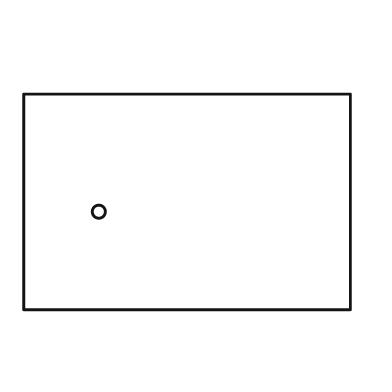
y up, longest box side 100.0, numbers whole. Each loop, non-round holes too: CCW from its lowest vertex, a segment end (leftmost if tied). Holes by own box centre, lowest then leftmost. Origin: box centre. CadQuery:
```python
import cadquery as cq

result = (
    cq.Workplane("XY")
    .moveTo(-50.0, -33.0)
    .lineTo(50.0, -33.0)
    .lineTo(50.0, 33.0)
    .lineTo(-50.0, 33.0)
    .close()
    .moveTo(-27.0, -3.0)
    .circle(2.0)
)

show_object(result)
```